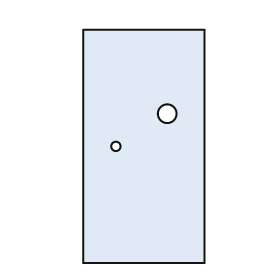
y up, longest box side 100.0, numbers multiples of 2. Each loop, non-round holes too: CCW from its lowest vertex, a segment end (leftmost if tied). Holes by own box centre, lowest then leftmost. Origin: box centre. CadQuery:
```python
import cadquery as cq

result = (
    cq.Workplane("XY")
    .moveTo(-26.0, -50.0)
    .lineTo(26.0, -50.0)
    .lineTo(26.0, 50.0)
    .lineTo(-26.0, 50.0)
    .close()
    .moveTo(-12.0, 0.0)
    .circle(2.0)
    .moveTo(10.0, 14.0)
    .circle(4.0)
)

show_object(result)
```